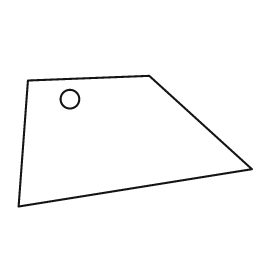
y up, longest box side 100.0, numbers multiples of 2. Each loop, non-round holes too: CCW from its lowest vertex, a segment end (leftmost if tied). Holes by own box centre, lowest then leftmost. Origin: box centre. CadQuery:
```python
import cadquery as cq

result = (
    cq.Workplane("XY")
    .moveTo(-50.0, -28.0)
    .lineTo(50.0, -12.0)
    .lineTo(6.0, 28.0)
    .lineTo(-46.0, 26.0)
    .close()
    .moveTo(-28.0, 18.0)
    .circle(4.0)
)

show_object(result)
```